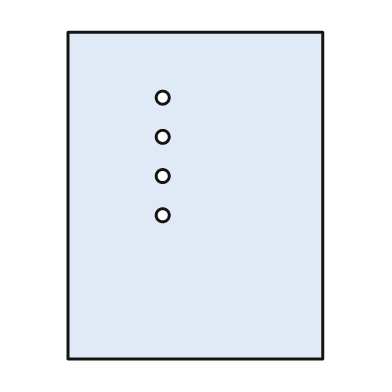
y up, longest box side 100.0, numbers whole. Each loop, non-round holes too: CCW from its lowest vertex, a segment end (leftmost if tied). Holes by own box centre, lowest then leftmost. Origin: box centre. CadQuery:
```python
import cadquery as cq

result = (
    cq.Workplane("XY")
    .moveTo(-39.0, -50.0)
    .lineTo(39.0, -50.0)
    .lineTo(39.0, 50.0)
    .lineTo(-39.0, 50.0)
    .close()
    .moveTo(-10.0, -6.0)
    .circle(2.0)
    .moveTo(-10.0, 6.0)
    .circle(2.0)
    .moveTo(-10.0, 18.0)
    .circle(2.0)
    .moveTo(-10.0, 30.0)
    .circle(2.0)
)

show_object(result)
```